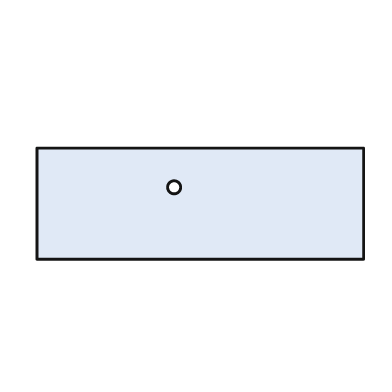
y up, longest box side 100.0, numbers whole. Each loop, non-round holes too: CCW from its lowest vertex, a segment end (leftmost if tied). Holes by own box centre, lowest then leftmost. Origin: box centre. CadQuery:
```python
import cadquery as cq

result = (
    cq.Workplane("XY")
    .moveTo(-50.0, -17.0)
    .lineTo(50.0, -17.0)
    .lineTo(50.0, 17.0)
    .lineTo(-50.0, 17.0)
    .close()
    .moveTo(-8.0, 5.0)
    .circle(2.0)
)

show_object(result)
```